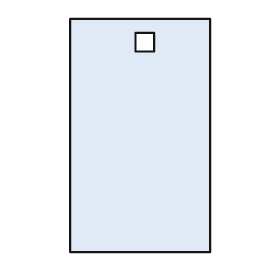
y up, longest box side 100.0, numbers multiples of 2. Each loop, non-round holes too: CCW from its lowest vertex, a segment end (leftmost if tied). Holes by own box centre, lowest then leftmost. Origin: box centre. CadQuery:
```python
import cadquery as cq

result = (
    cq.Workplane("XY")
    .moveTo(-30.0, -50.0)
    .lineTo(30.0, -50.0)
    .lineTo(30.0, 50.0)
    .lineTo(-30.0, 50.0)
    .close()
    .moveTo(-2.0, 36.0)
    .lineTo(6.0, 36.0)
    .lineTo(6.0, 44.0)
    .lineTo(-2.0, 44.0)
    .close()
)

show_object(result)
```